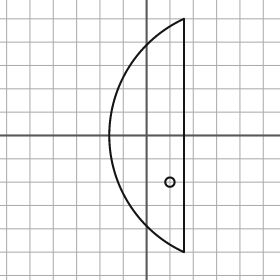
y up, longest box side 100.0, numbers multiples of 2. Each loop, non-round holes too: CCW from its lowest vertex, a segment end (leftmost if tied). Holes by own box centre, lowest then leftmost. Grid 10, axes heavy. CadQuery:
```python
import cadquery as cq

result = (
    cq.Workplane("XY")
    .moveTo(16.0, -50.0)
    .lineTo(16.0, 50.0)
    .threePointArc((-16.0, 0.0), (16.0, -50.0))
    .close()
    .moveTo(10.0, -20.0)
    .circle(2.0)
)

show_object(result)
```